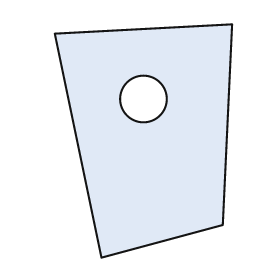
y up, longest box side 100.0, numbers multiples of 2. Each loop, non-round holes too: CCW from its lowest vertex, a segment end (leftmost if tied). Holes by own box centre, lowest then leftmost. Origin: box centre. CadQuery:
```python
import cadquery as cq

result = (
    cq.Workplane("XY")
    .moveTo(-18.0, -50.0)
    .lineTo(34.0, -36.0)
    .lineTo(38.0, 50.0)
    .lineTo(-38.0, 46.0)
    .close()
    .moveTo(0.0, 18.0)
    .circle(10.0)
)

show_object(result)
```